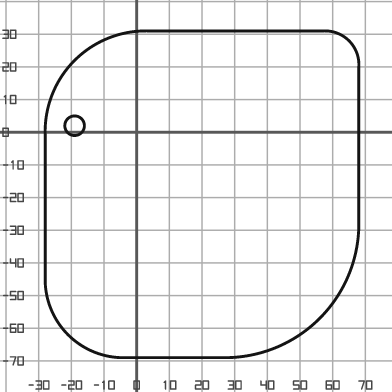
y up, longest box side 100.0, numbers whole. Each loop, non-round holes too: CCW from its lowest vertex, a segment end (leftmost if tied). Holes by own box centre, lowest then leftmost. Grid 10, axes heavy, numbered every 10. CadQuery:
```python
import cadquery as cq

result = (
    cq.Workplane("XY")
    .moveTo(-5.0, -69.0)
    .lineTo(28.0, -69.0)
    .threePointArc((56.0, -57.0), (68.0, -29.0))
    .lineTo(68.0, 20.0)
    .threePointArc((65.0, 28.0), (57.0, 31.0))
    .lineTo(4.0, 31.0)
    .threePointArc((-19.0, 22.0), (-28.0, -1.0))
    .lineTo(-28.0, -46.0)
    .threePointArc((-21.0, -62.0), (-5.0, -69.0))
    .close()
    .moveTo(-19.0, 2.0)
    .circle(3.0)
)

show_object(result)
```